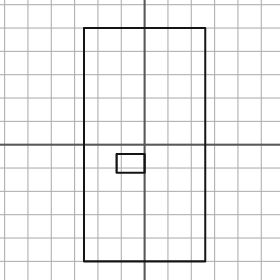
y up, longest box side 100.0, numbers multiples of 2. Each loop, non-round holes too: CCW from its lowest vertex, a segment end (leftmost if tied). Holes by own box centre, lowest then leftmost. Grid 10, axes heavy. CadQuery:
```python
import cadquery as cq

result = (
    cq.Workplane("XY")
    .moveTo(-26.0, -50.0)
    .lineTo(26.0, -50.0)
    .lineTo(26.0, 50.0)
    .lineTo(-26.0, 50.0)
    .close()
    .moveTo(-12.0, -12.0)
    .lineTo(0.0, -12.0)
    .lineTo(0.0, -4.0)
    .lineTo(-12.0, -4.0)
    .close()
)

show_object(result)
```